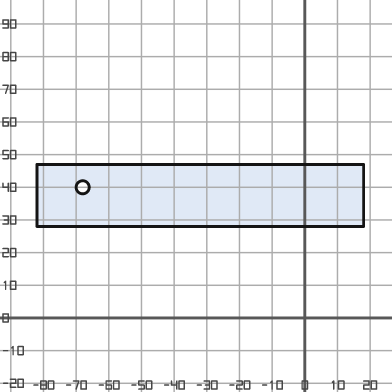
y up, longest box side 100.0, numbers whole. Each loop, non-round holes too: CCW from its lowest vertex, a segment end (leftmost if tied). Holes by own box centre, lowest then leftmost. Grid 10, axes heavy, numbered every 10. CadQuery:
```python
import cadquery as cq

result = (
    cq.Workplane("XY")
    .moveTo(-82.0, 28.0)
    .lineTo(18.0, 28.0)
    .lineTo(18.0, 47.0)
    .lineTo(-82.0, 47.0)
    .close()
    .moveTo(-68.0, 40.0)
    .circle(2.0)
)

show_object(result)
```